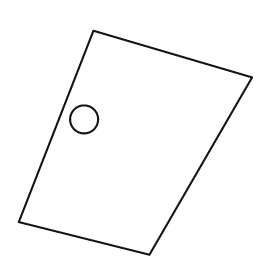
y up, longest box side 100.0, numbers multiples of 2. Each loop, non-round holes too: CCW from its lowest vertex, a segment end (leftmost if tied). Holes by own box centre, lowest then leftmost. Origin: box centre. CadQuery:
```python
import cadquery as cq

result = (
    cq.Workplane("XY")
    .moveTo(6.0, -48.0)
    .lineTo(50.0, 28.0)
    .lineTo(-18.0, 48.0)
    .lineTo(-50.0, -34.0)
    .close()
    .moveTo(-22.0, 10.0)
    .circle(6.0)
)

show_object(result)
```